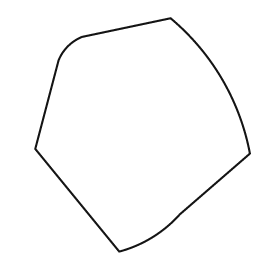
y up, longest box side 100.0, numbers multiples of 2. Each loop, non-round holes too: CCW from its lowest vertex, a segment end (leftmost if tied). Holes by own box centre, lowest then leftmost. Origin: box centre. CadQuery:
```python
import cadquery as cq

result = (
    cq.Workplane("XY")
    .moveTo(-10.0, -50.0)
    .threePointArc((4.0, -44.0), (16.0, -34.0))
    .lineTo(46.0, -8.0)
    .threePointArc((34.0, 24.0), (12.0, 50.0))
    .lineTo(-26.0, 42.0)
    .threePointArc((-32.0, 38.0), (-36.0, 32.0))
    .lineTo(-46.0, -6.0)
    .close()
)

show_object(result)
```